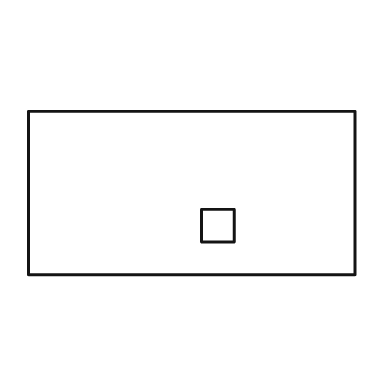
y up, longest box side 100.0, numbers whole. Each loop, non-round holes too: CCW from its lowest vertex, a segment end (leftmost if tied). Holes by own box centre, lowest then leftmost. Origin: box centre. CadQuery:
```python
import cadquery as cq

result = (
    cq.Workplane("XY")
    .moveTo(-50.0, -25.0)
    .lineTo(50.0, -25.0)
    .lineTo(50.0, 25.0)
    .lineTo(-50.0, 25.0)
    .close()
    .moveTo(3.0, -15.0)
    .lineTo(13.0, -15.0)
    .lineTo(13.0, -5.0)
    .lineTo(3.0, -5.0)
    .close()
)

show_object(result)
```